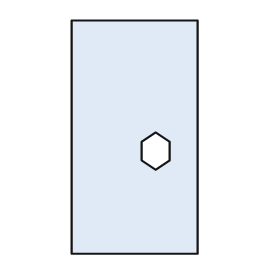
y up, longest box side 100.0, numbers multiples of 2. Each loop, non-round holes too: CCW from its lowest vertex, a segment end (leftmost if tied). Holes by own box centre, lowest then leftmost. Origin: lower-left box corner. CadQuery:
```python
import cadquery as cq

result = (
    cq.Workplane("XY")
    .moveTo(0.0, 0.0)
    .lineTo(54.0, 0.0)
    .lineTo(54.0, 100.0)
    .lineTo(0.0, 100.0)
    .close()
    .moveTo(36.0, 36.0)
    .lineTo(42.0, 40.0)
    .lineTo(42.0, 48.0)
    .lineTo(36.0, 52.0)
    .lineTo(30.0, 48.0)
    .lineTo(30.0, 40.0)
    .close()
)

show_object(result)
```